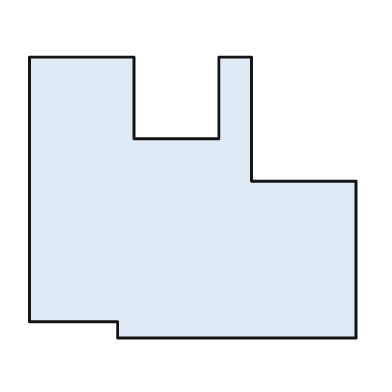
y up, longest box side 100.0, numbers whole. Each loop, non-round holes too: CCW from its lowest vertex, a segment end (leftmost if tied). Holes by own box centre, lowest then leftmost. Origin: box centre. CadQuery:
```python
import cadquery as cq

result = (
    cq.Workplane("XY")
    .moveTo(-23.0, -43.0)
    .lineTo(50.0, -43.0)
    .lineTo(50.0, 5.0)
    .lineTo(18.0, 5.0)
    .lineTo(18.0, 43.0)
    .lineTo(8.0, 43.0)
    .lineTo(8.0, 18.0)
    .lineTo(-18.0, 18.0)
    .lineTo(-18.0, 43.0)
    .lineTo(-50.0, 43.0)
    .lineTo(-50.0, -38.0)
    .lineTo(-23.0, -38.0)
    .close()
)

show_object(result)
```